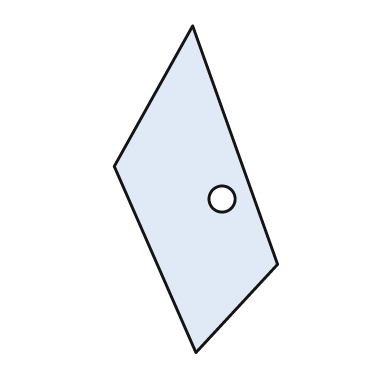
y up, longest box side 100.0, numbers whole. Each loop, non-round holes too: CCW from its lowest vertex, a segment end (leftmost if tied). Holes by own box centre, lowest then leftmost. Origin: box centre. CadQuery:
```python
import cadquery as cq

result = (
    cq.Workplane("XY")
    .moveTo(0.0, -50.0)
    .lineTo(25.0, -23.0)
    .lineTo(-1.0, 50.0)
    .lineTo(-25.0, 7.0)
    .close()
    .moveTo(8.0, -3.0)
    .circle(4.0)
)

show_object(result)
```